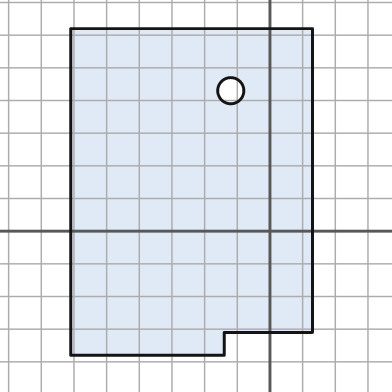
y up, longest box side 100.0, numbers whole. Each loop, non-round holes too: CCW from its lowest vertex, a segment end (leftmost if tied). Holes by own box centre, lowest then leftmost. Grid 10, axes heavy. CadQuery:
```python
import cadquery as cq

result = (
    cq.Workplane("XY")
    .moveTo(-61.0, -38.0)
    .lineTo(-14.0, -38.0)
    .lineTo(-14.0, -31.0)
    .lineTo(13.0, -31.0)
    .lineTo(13.0, 62.0)
    .lineTo(-61.0, 62.0)
    .close()
    .moveTo(-12.0, 43.0)
    .circle(4.0)
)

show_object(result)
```